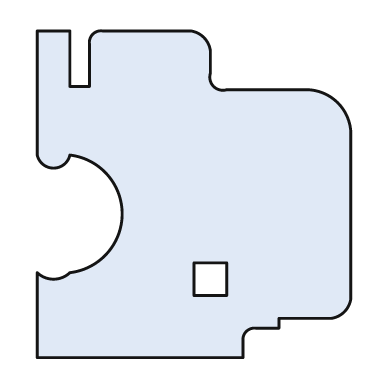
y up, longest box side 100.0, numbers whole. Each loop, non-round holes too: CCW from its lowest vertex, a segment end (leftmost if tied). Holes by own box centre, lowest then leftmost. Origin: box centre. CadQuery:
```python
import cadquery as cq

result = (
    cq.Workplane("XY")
    .moveTo(-48.0, -50.0)
    .lineTo(15.0, -50.0)
    .lineTo(15.0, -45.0)
    .threePointArc((16.0, -42.0), (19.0, -41.0))
    .lineTo(26.0, -41.0)
    .lineTo(26.0, -38.0)
    .lineTo(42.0, -38.0)
    .threePointArc((46.0, -36.0), (48.0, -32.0))
    .lineTo(48.0, 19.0)
    .threePointArc((44.0, 28.0), (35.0, 32.0))
    .lineTo(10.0, 32.0)
    .threePointArc((6.0, 33.0), (5.0, 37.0))
    .lineTo(5.0, 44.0)
    .threePointArc((3.0, 48.0), (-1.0, 50.0))
    .lineTo(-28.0, 50.0)
    .threePointArc((-31.0, 49.0), (-32.0, 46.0))
    .lineTo(-32.0, 33.0)
    .lineTo(-38.0, 33.0)
    .lineTo(-38.0, 50.0)
    .lineTo(-48.0, 50.0)
    .lineTo(-48.0, 12.0)
    .threePointArc((-43.0, 8.0), (-38.0, 12.0))
    .threePointArc((-22.0, -6.0), (-38.0, -24.0))
    .threePointArc((-43.0, -26.0), (-48.0, -24.0))
    .close()
    .moveTo(0.0, -31.0)
    .lineTo(10.0, -31.0)
    .lineTo(10.0, -21.0)
    .lineTo(0.0, -21.0)
    .close()
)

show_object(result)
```